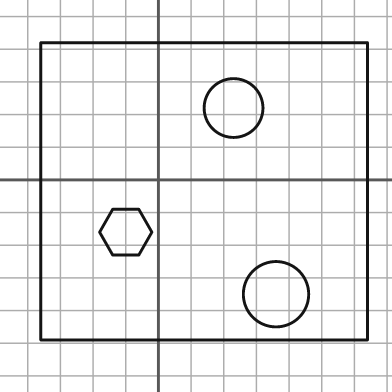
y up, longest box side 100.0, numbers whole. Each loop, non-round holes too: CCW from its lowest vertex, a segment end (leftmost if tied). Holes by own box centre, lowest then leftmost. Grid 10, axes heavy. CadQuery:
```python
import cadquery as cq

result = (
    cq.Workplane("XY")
    .moveTo(-36.0, -49.0)
    .lineTo(64.0, -49.0)
    .lineTo(64.0, 42.0)
    .lineTo(-36.0, 42.0)
    .close()
    .moveTo(36.0, -35.0)
    .circle(10.0)
    .moveTo(-14.0, -23.0)
    .lineTo(-6.0, -23.0)
    .lineTo(-2.0, -16.0)
    .lineTo(-6.0, -9.0)
    .lineTo(-14.0, -9.0)
    .lineTo(-18.0, -16.0)
    .close()
    .moveTo(23.0, 22.0)
    .circle(9.0)
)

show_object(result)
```